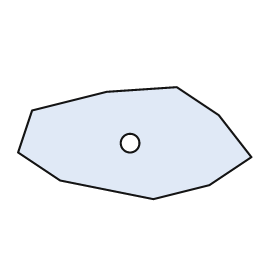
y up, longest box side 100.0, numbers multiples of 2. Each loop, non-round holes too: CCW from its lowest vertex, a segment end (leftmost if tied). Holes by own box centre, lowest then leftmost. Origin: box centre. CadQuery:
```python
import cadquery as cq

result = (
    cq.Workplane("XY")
    .moveTo(8.0, -24.0)
    .lineTo(32.0, -18.0)
    .lineTo(50.0, -6.0)
    .lineTo(36.0, 12.0)
    .lineTo(18.0, 24.0)
    .lineTo(-12.0, 22.0)
    .lineTo(-44.0, 14.0)
    .lineTo(-50.0, -4.0)
    .lineTo(-32.0, -16.0)
    .close()
    .moveTo(-2.0, 0.0)
    .circle(4.0)
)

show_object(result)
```